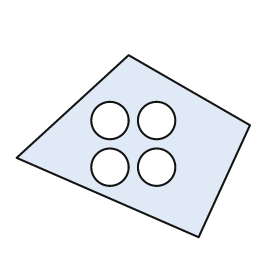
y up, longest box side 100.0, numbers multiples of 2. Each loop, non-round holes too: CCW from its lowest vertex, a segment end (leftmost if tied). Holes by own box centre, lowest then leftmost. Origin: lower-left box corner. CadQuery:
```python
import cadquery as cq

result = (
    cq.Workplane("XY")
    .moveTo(78.0, 0.0)
    .lineTo(100.0, 48.0)
    .lineTo(48.0, 78.0)
    .lineTo(0.0, 34.0)
    .close()
    .moveTo(40.0, 30.0)
    .circle(8.0)
    .moveTo(60.0, 30.0)
    .circle(8.0)
    .moveTo(40.0, 50.0)
    .circle(8.0)
    .moveTo(60.0, 50.0)
    .circle(8.0)
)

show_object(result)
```